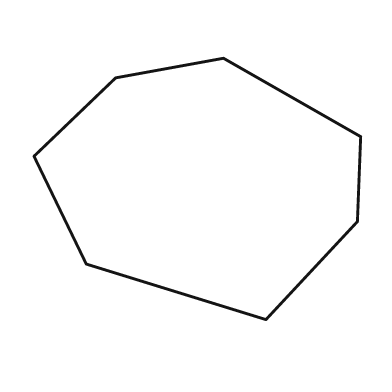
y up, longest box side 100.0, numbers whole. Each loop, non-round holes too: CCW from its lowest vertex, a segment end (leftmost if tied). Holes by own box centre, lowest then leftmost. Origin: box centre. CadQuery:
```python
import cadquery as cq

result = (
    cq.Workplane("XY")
    .moveTo(21.0, -40.0)
    .lineTo(49.0, -10.0)
    .lineTo(50.0, 16.0)
    .lineTo(8.0, 40.0)
    .lineTo(-25.0, 34.0)
    .lineTo(-50.0, 10.0)
    .lineTo(-34.0, -23.0)
    .close()
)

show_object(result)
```